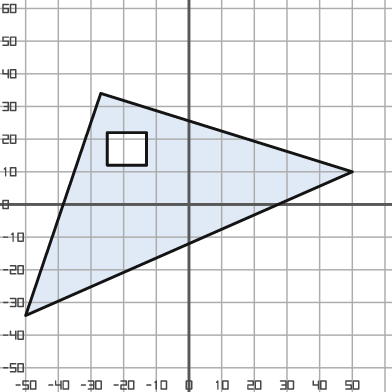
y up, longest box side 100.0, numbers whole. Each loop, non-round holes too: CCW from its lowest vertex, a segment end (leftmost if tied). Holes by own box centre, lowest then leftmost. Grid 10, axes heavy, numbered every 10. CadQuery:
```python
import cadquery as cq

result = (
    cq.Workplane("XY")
    .moveTo(-50.0, -34.0)
    .lineTo(50.0, 10.0)
    .lineTo(-27.0, 34.0)
    .close()
    .moveTo(-25.0, 12.0)
    .lineTo(-13.0, 12.0)
    .lineTo(-13.0, 22.0)
    .lineTo(-25.0, 22.0)
    .close()
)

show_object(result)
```